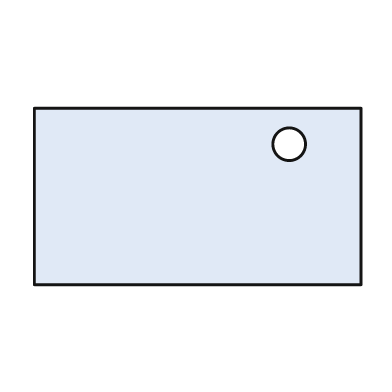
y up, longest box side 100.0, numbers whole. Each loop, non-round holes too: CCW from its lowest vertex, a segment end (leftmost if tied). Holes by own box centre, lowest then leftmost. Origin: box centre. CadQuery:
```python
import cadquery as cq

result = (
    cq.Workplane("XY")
    .moveTo(-50.0, -27.0)
    .lineTo(50.0, -27.0)
    .lineTo(50.0, 27.0)
    .lineTo(-50.0, 27.0)
    .close()
    .moveTo(28.0, 16.0)
    .circle(5.0)
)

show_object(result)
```